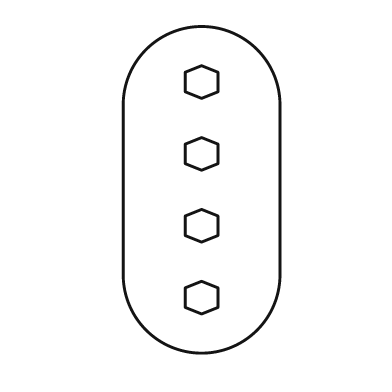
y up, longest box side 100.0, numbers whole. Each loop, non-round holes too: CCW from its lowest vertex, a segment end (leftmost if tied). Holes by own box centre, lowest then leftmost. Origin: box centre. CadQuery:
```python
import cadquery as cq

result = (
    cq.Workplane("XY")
    .moveTo(-24.0, -26.0)
    .threePointArc((0.0, -50.0), (24.0, -26.0))
    .lineTo(24.0, 26.0)
    .threePointArc((0.0, 50.0), (-24.0, 26.0))
    .close()
    .moveTo(0.0, -38.0)
    .lineTo(5.0, -36.0)
    .lineTo(5.0, -30.0)
    .lineTo(0.0, -28.0)
    .lineTo(-5.0, -30.0)
    .lineTo(-5.0, -36.0)
    .close()
    .moveTo(0.0, -16.0)
    .lineTo(5.0, -14.0)
    .lineTo(5.0, -8.0)
    .lineTo(0.0, -6.0)
    .lineTo(-5.0, -8.0)
    .lineTo(-5.0, -14.0)
    .close()
    .moveTo(0.0, 6.0)
    .lineTo(5.0, 8.0)
    .lineTo(5.0, 14.0)
    .lineTo(0.0, 16.0)
    .lineTo(-5.0, 14.0)
    .lineTo(-5.0, 8.0)
    .close()
    .moveTo(0.0, 28.0)
    .lineTo(5.0, 30.0)
    .lineTo(5.0, 36.0)
    .lineTo(0.0, 38.0)
    .lineTo(-5.0, 36.0)
    .lineTo(-5.0, 30.0)
    .close()
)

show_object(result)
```